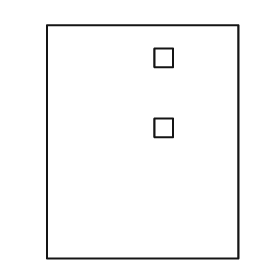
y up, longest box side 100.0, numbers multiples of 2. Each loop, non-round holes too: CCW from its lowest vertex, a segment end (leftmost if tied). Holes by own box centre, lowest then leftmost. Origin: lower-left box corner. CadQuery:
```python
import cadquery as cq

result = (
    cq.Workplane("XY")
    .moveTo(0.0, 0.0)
    .lineTo(82.0, 0.0)
    .lineTo(82.0, 100.0)
    .lineTo(0.0, 100.0)
    .close()
    .moveTo(46.0, 52.0)
    .lineTo(54.0, 52.0)
    .lineTo(54.0, 60.0)
    .lineTo(46.0, 60.0)
    .close()
    .moveTo(46.0, 82.0)
    .lineTo(54.0, 82.0)
    .lineTo(54.0, 90.0)
    .lineTo(46.0, 90.0)
    .close()
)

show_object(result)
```